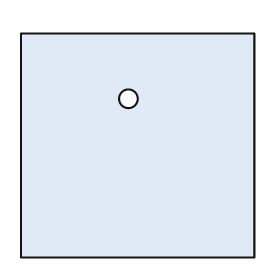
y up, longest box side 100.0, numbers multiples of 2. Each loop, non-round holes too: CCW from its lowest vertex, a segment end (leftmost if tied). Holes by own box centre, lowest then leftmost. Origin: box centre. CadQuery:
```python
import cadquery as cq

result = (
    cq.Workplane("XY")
    .moveTo(-50.0, -48.0)
    .lineTo(50.0, -48.0)
    .lineTo(50.0, 48.0)
    .lineTo(-50.0, 48.0)
    .close()
    .moveTo(-4.0, 20.0)
    .circle(4.0)
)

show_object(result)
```